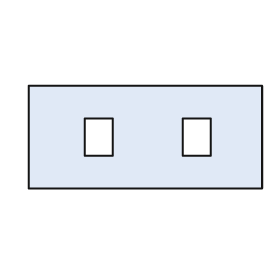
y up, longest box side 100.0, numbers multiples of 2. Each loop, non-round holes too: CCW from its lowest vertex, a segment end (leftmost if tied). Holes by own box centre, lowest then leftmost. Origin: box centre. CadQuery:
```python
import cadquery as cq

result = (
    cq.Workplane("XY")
    .moveTo(-50.0, -22.0)
    .lineTo(50.0, -22.0)
    .lineTo(50.0, 22.0)
    .lineTo(-50.0, 22.0)
    .close()
    .moveTo(-26.0, -8.0)
    .lineTo(-14.0, -8.0)
    .lineTo(-14.0, 8.0)
    .lineTo(-26.0, 8.0)
    .close()
    .moveTo(16.0, -8.0)
    .lineTo(28.0, -8.0)
    .lineTo(28.0, 8.0)
    .lineTo(16.0, 8.0)
    .close()
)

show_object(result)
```